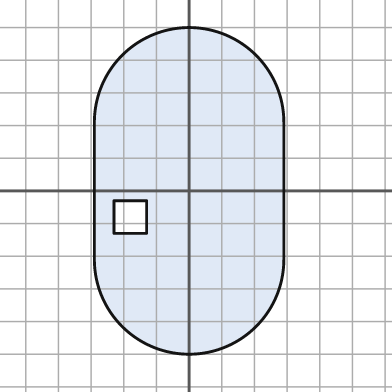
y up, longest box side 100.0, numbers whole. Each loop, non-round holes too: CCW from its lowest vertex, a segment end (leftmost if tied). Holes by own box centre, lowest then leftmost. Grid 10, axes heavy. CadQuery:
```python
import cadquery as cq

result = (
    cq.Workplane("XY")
    .moveTo(-29.0, -21.0)
    .threePointArc((0.0, -50.0), (29.0, -21.0))
    .lineTo(29.0, 21.0)
    .threePointArc((0.0, 50.0), (-29.0, 21.0))
    .close()
    .moveTo(-23.0, -13.0)
    .lineTo(-13.0, -13.0)
    .lineTo(-13.0, -3.0)
    .lineTo(-23.0, -3.0)
    .close()
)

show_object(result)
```